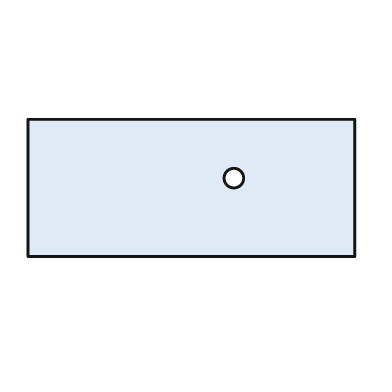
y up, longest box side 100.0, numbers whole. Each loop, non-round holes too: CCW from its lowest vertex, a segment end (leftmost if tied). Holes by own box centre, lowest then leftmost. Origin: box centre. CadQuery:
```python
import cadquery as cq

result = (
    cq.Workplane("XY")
    .moveTo(-50.0, -21.0)
    .lineTo(50.0, -21.0)
    .lineTo(50.0, 21.0)
    .lineTo(-50.0, 21.0)
    .close()
    .moveTo(13.0, 3.0)
    .circle(3.0)
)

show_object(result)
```